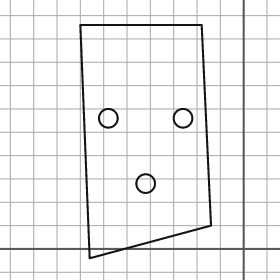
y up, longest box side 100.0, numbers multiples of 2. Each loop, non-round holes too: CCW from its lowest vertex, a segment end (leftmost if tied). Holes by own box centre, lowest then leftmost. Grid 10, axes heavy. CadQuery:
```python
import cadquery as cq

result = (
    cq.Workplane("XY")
    .moveTo(-66.0, -4.0)
    .lineTo(-14.0, 10.0)
    .lineTo(-18.0, 96.0)
    .lineTo(-70.0, 96.0)
    .close()
    .moveTo(-42.0, 28.0)
    .circle(4.0)
    .moveTo(-58.0, 56.0)
    .circle(4.0)
    .moveTo(-26.0, 56.0)
    .circle(4.0)
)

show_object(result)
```